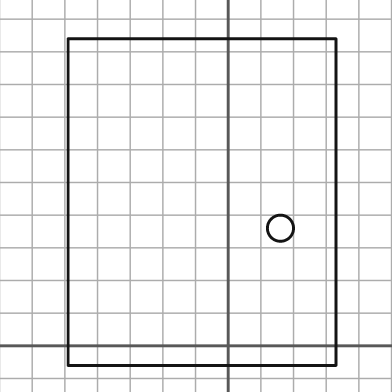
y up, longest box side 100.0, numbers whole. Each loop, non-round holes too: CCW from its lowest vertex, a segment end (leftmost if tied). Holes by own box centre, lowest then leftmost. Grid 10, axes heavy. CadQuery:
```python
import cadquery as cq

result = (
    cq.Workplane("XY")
    .moveTo(-49.0, -6.0)
    .lineTo(33.0, -6.0)
    .lineTo(33.0, 94.0)
    .lineTo(-49.0, 94.0)
    .close()
    .moveTo(16.0, 36.0)
    .circle(4.0)
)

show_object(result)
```